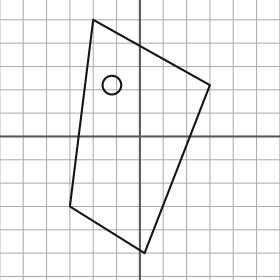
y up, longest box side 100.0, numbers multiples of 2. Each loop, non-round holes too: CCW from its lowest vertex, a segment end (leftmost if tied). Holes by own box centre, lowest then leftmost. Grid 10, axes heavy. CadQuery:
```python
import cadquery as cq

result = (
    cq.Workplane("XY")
    .moveTo(2.0, -50.0)
    .lineTo(30.0, 22.0)
    .lineTo(-20.0, 50.0)
    .lineTo(-30.0, -30.0)
    .close()
    .moveTo(-12.0, 22.0)
    .circle(4.0)
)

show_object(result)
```